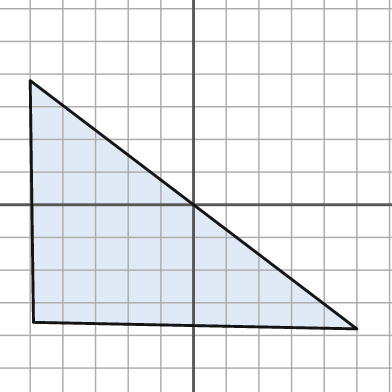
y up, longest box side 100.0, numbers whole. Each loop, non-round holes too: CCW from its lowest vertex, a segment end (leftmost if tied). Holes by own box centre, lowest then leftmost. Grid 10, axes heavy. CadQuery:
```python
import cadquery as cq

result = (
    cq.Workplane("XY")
    .moveTo(50.0, -38.0)
    .lineTo(-50.0, 38.0)
    .lineTo(-49.0, -36.0)
    .close()
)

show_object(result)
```